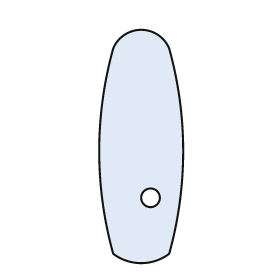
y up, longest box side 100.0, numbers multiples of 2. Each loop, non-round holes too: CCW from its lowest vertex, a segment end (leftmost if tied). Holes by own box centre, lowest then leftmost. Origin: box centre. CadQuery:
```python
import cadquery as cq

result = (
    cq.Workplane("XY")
    .moveTo(-12.0, -46.0)
    .threePointArc((0.0, -50.0), (12.0, -46.0))
    .threePointArc((18.0, -2.0), (12.0, 42.0))
    .threePointArc((0.0, 50.0), (-12.0, 42.0))
    .threePointArc((-18.0, -2.0), (-12.0, -46.0))
    .close()
    .moveTo(4.0, -22.0)
    .circle(4.0)
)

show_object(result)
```